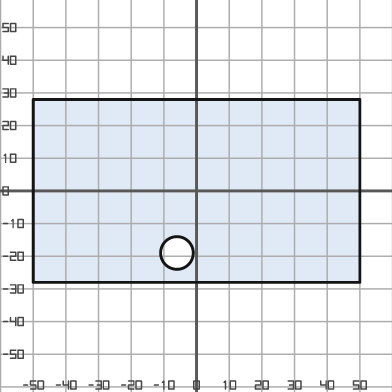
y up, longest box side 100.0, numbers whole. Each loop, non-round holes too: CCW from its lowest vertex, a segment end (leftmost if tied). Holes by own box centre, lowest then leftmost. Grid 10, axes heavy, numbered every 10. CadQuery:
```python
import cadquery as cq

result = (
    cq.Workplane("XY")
    .moveTo(-50.0, -28.0)
    .lineTo(50.0, -28.0)
    .lineTo(50.0, 28.0)
    .lineTo(-50.0, 28.0)
    .close()
    .moveTo(-6.0, -19.0)
    .circle(5.0)
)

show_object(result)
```